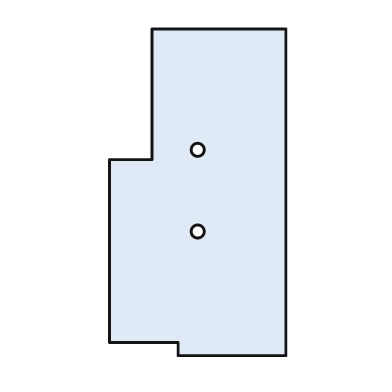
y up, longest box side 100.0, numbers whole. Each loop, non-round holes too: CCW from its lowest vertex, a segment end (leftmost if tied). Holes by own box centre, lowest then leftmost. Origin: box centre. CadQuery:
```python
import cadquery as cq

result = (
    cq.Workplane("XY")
    .moveTo(-6.0, -50.0)
    .lineTo(27.0, -50.0)
    .lineTo(27.0, 50.0)
    .lineTo(-14.0, 50.0)
    .lineTo(-14.0, 10.0)
    .lineTo(-27.0, 10.0)
    .lineTo(-27.0, -46.0)
    .lineTo(-6.0, -46.0)
    .close()
    .moveTo(0.0, -12.0)
    .circle(2.0)
    .moveTo(0.0, 13.0)
    .circle(2.0)
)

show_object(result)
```